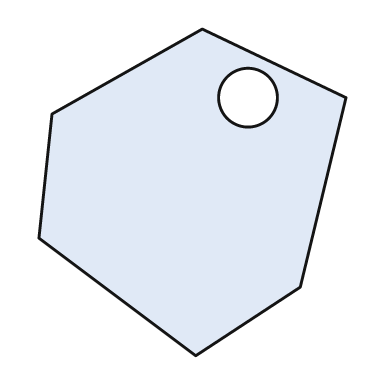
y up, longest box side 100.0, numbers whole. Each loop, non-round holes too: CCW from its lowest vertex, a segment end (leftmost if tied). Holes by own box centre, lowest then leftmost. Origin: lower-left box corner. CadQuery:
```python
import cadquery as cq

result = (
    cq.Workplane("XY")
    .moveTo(48.0, 0.0)
    .lineTo(80.0, 21.0)
    .lineTo(94.0, 79.0)
    .lineTo(50.0, 100.0)
    .lineTo(4.0, 74.0)
    .lineTo(0.0, 36.0)
    .close()
    .moveTo(64.0, 79.0)
    .circle(9.0)
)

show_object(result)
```